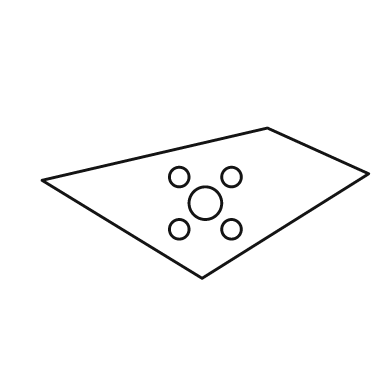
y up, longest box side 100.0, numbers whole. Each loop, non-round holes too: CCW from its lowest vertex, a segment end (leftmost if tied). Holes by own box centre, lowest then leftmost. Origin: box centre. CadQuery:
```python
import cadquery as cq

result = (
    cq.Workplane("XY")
    .moveTo(-1.0, -23.0)
    .lineTo(50.0, 9.0)
    .lineTo(19.0, 23.0)
    .lineTo(-50.0, 7.0)
    .close()
    .moveTo(-8.0, -8.0)
    .circle(3.0)
    .moveTo(8.0, -8.0)
    .circle(3.0)
    .moveTo(0.0, 0.0)
    .circle(5.0)
    .moveTo(-8.0, 8.0)
    .circle(3.0)
    .moveTo(8.0, 8.0)
    .circle(3.0)
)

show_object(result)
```